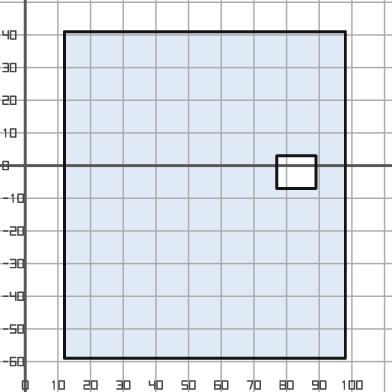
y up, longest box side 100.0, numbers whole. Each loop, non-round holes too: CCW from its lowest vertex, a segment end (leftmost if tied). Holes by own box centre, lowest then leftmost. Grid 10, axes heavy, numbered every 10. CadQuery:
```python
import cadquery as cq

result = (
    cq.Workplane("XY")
    .moveTo(12.0, -59.0)
    .lineTo(98.0, -59.0)
    .lineTo(98.0, 41.0)
    .lineTo(12.0, 41.0)
    .close()
    .moveTo(77.0, -7.0)
    .lineTo(89.0, -7.0)
    .lineTo(89.0, 3.0)
    .lineTo(77.0, 3.0)
    .close()
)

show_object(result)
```